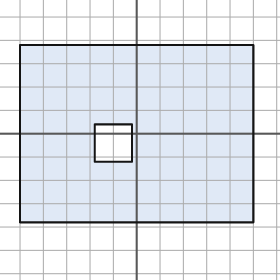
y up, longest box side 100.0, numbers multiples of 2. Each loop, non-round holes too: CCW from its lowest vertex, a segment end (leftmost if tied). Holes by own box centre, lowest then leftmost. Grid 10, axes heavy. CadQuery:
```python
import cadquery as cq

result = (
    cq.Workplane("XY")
    .moveTo(-50.0, -38.0)
    .lineTo(50.0, -38.0)
    .lineTo(50.0, 38.0)
    .lineTo(-50.0, 38.0)
    .close()
    .moveTo(-18.0, -12.0)
    .lineTo(-2.0, -12.0)
    .lineTo(-2.0, 4.0)
    .lineTo(-18.0, 4.0)
    .close()
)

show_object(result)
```